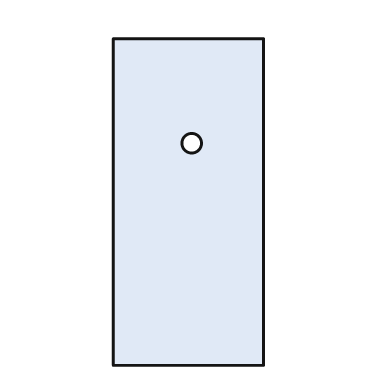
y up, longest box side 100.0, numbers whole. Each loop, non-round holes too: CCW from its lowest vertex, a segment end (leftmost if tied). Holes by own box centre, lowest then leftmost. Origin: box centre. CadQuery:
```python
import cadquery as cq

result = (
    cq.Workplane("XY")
    .moveTo(-23.0, -50.0)
    .lineTo(23.0, -50.0)
    .lineTo(23.0, 50.0)
    .lineTo(-23.0, 50.0)
    .close()
    .moveTo(1.0, 18.0)
    .circle(3.0)
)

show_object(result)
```